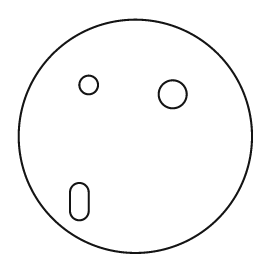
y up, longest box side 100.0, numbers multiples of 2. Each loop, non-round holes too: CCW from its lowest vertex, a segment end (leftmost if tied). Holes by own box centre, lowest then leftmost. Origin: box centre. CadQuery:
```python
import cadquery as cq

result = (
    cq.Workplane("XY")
    .moveTo(0.0, 0.0)
    .circle(50.0)
    .moveTo(-28.0, -32.0)
    .threePointArc((-24.0, -36.0), (-20.0, -32.0))
    .lineTo(-20.0, -24.0)
    .threePointArc((-24.0, -20.0), (-28.0, -24.0))
    .close()
    .moveTo(16.0, 18.0)
    .circle(6.0)
    .moveTo(-20.0, 22.0)
    .circle(4.0)
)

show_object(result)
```